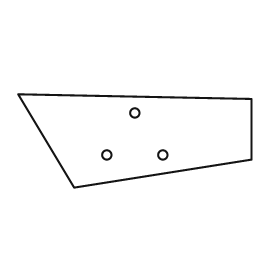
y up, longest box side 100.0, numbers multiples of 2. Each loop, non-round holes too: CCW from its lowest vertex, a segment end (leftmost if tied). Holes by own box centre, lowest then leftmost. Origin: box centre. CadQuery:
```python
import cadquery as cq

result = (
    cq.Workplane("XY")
    .moveTo(-26.0, -20.0)
    .lineTo(50.0, -8.0)
    .lineTo(50.0, 18.0)
    .lineTo(-50.0, 20.0)
    .close()
    .moveTo(-12.0, -6.0)
    .circle(2.0)
    .moveTo(12.0, -6.0)
    .circle(2.0)
    .moveTo(0.0, 12.0)
    .circle(2.0)
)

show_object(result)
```